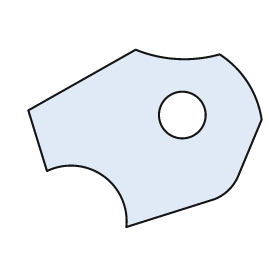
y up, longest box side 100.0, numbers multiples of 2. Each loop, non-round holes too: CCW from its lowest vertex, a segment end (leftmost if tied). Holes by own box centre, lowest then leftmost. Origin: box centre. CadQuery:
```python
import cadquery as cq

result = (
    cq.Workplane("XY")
    .moveTo(-8.0, -38.0)
    .lineTo(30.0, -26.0)
    .threePointArc((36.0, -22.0), (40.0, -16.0))
    .lineTo(50.0, 8.0)
    .threePointArc((44.0, 24.0), (32.0, 36.0))
    .threePointArc((14.0, 34.0), (-4.0, 38.0))
    .lineTo(-50.0, 12.0)
    .lineTo(-42.0, -14.0)
    .threePointArc((-18.0, -16.0), (-8.0, -38.0))
    .close()
    .moveTo(16.0, 10.0)
    .circle(10.0)
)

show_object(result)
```